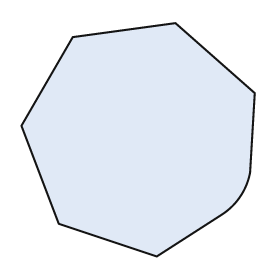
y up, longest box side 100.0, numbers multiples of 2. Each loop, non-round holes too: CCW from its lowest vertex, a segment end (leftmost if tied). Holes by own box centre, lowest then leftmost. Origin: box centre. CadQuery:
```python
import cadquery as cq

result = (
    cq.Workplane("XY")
    .moveTo(8.0, -50.0)
    .lineTo(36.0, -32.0)
    .threePointArc((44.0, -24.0), (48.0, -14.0))
    .lineTo(50.0, 20.0)
    .lineTo(16.0, 50.0)
    .lineTo(-28.0, 44.0)
    .lineTo(-50.0, 6.0)
    .lineTo(-34.0, -36.0)
    .close()
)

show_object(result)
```